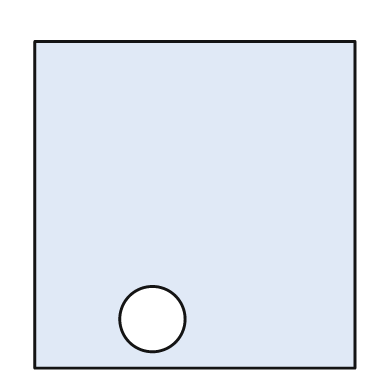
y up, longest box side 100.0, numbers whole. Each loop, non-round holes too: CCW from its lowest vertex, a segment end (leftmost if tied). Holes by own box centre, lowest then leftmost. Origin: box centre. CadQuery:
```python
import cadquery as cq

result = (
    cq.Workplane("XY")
    .moveTo(-49.0, -50.0)
    .lineTo(49.0, -50.0)
    .lineTo(49.0, 50.0)
    .lineTo(-49.0, 50.0)
    .close()
    .moveTo(-13.0, -35.0)
    .circle(10.0)
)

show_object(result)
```